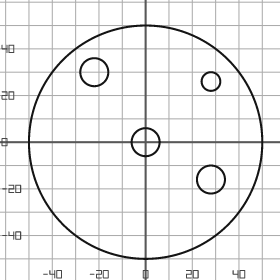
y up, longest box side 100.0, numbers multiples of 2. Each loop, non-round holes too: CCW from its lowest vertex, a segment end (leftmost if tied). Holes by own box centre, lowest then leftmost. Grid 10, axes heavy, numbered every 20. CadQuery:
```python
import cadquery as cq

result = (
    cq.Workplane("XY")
    .moveTo(0.0, 0.0)
    .circle(50.0)
    .moveTo(28.0, -16.0)
    .circle(6.0)
    .moveTo(0.0, 0.0)
    .circle(6.0)
    .moveTo(28.0, 26.0)
    .circle(4.0)
    .moveTo(-22.0, 30.0)
    .circle(6.0)
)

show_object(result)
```